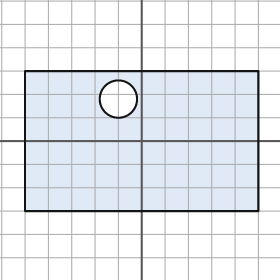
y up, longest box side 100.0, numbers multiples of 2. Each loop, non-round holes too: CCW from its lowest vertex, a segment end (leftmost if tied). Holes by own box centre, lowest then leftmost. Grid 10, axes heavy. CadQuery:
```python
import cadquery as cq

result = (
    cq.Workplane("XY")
    .moveTo(-50.0, -30.0)
    .lineTo(50.0, -30.0)
    .lineTo(50.0, 30.0)
    .lineTo(-50.0, 30.0)
    .close()
    .moveTo(-10.0, 18.0)
    .circle(8.0)
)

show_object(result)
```